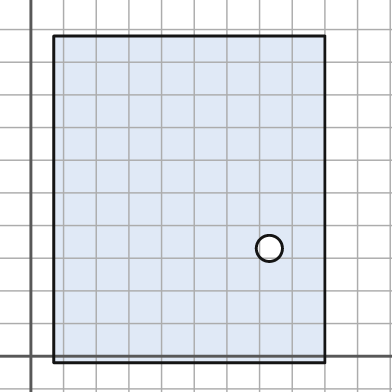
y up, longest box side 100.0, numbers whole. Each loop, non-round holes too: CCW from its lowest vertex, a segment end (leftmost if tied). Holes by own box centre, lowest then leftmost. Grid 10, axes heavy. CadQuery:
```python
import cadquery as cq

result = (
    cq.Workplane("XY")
    .moveTo(7.0, -2.0)
    .lineTo(90.0, -2.0)
    .lineTo(90.0, 98.0)
    .lineTo(7.0, 98.0)
    .close()
    .moveTo(73.0, 33.0)
    .circle(4.0)
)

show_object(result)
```